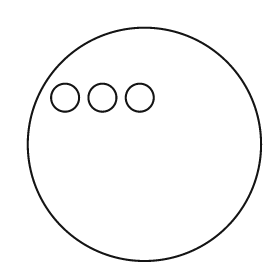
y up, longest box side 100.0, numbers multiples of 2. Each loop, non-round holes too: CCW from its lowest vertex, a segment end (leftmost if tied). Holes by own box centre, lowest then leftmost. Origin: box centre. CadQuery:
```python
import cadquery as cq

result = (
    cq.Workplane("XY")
    .moveTo(0.0, 0.0)
    .circle(50.0)
    .moveTo(-34.0, 20.0)
    .circle(6.0)
    .moveTo(-18.0, 20.0)
    .circle(6.0)
    .moveTo(-2.0, 20.0)
    .circle(6.0)
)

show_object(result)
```